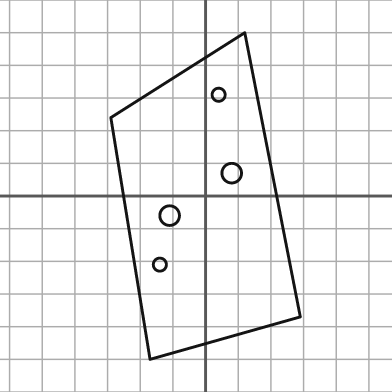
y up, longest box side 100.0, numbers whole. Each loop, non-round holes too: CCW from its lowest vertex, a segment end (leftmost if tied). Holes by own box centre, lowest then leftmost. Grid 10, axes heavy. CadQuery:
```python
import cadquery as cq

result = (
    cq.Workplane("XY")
    .moveTo(-17.0, -50.0)
    .lineTo(29.0, -37.0)
    .lineTo(12.0, 50.0)
    .lineTo(-29.0, 24.0)
    .close()
    .moveTo(-14.0, -21.0)
    .circle(2.0)
    .moveTo(-11.0, -6.0)
    .circle(3.0)
    .moveTo(8.0, 7.0)
    .circle(3.0)
    .moveTo(4.0, 31.0)
    .circle(2.0)
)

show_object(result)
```